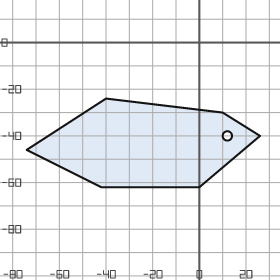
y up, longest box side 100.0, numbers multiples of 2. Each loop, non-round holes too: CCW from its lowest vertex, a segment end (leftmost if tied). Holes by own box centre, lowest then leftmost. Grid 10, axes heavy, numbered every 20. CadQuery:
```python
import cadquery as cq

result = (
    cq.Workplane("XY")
    .moveTo(-42.0, -62.0)
    .lineTo(0.0, -62.0)
    .lineTo(26.0, -40.0)
    .lineTo(10.0, -30.0)
    .lineTo(-40.0, -24.0)
    .lineTo(-74.0, -46.0)
    .close()
    .moveTo(12.0, -40.0)
    .circle(2.0)
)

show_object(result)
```